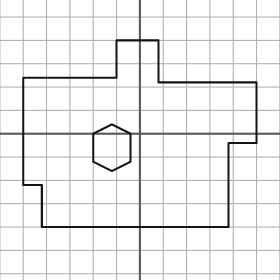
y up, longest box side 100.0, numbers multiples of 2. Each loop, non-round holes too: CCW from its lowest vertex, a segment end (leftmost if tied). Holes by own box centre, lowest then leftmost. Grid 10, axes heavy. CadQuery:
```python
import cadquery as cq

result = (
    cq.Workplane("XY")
    .moveTo(-42.0, -40.0)
    .lineTo(38.0, -40.0)
    .lineTo(38.0, -4.0)
    .lineTo(50.0, -4.0)
    .lineTo(50.0, 22.0)
    .lineTo(8.0, 22.0)
    .lineTo(8.0, 40.0)
    .lineTo(-10.0, 40.0)
    .lineTo(-10.0, 24.0)
    .lineTo(-50.0, 24.0)
    .lineTo(-50.0, -22.0)
    .lineTo(-42.0, -22.0)
    .close()
    .moveTo(-12.0, -16.0)
    .lineTo(-4.0, -12.0)
    .lineTo(-4.0, 0.0)
    .lineTo(-12.0, 4.0)
    .lineTo(-20.0, 0.0)
    .lineTo(-20.0, -12.0)
    .close()
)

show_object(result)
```